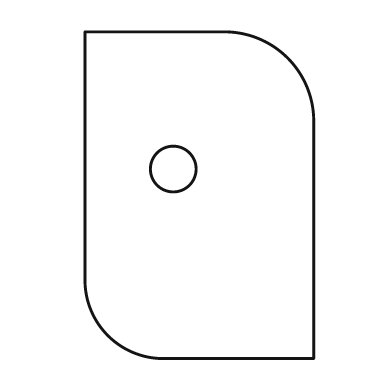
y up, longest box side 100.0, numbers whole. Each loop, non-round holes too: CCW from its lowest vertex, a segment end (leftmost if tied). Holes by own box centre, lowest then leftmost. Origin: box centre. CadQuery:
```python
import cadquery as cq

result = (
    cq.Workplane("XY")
    .moveTo(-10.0, -50.0)
    .lineTo(35.0, -50.0)
    .lineTo(35.0, 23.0)
    .threePointArc((27.0, 42.0), (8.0, 50.0))
    .lineTo(-35.0, 50.0)
    .lineTo(-35.0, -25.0)
    .threePointArc((-28.0, -43.0), (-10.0, -50.0))
    .close()
    .moveTo(-8.0, 8.0)
    .circle(7.0)
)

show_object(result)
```